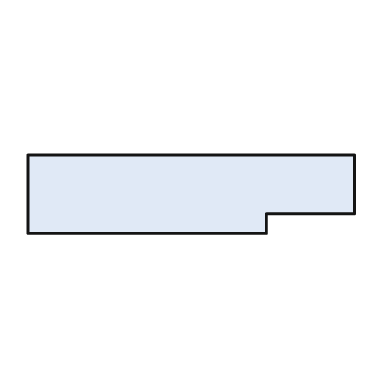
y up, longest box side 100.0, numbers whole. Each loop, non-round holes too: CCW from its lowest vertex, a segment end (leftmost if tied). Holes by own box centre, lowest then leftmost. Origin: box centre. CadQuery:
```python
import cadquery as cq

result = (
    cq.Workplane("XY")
    .moveTo(-50.0, -12.0)
    .lineTo(23.0, -12.0)
    .lineTo(23.0, -6.0)
    .lineTo(50.0, -6.0)
    .lineTo(50.0, 12.0)
    .lineTo(-50.0, 12.0)
    .close()
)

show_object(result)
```